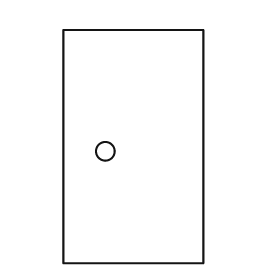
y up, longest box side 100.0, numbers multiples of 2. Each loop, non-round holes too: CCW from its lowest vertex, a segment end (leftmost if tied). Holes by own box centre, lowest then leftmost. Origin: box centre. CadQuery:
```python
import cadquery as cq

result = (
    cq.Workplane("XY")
    .moveTo(-30.0, -50.0)
    .lineTo(30.0, -50.0)
    .lineTo(30.0, 50.0)
    .lineTo(-30.0, 50.0)
    .close()
    .moveTo(-12.0, -2.0)
    .circle(4.0)
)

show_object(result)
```